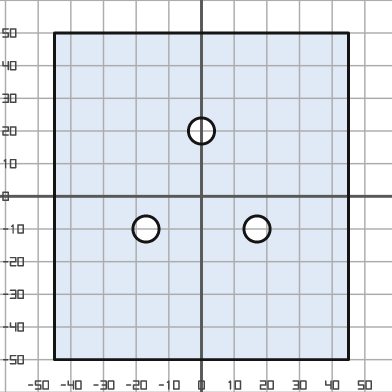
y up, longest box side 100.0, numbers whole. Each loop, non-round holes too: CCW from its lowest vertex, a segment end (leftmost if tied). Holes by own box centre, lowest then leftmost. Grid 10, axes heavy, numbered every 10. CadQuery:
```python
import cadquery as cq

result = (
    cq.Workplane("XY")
    .moveTo(-45.0, -50.0)
    .lineTo(45.0, -50.0)
    .lineTo(45.0, 50.0)
    .lineTo(-45.0, 50.0)
    .close()
    .moveTo(-17.0, -10.0)
    .circle(4.0)
    .moveTo(17.0, -10.0)
    .circle(4.0)
    .moveTo(0.0, 20.0)
    .circle(4.0)
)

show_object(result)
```